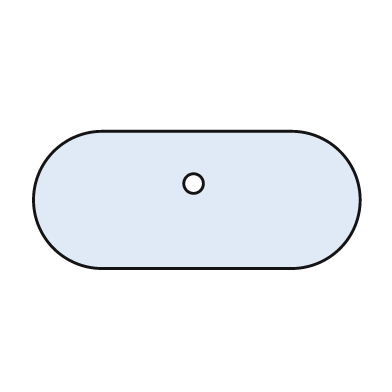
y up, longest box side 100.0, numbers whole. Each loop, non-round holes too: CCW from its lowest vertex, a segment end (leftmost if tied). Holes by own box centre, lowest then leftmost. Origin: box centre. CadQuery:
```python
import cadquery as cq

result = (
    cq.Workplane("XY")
    .moveTo(-29.0, -21.0)
    .lineTo(29.0, -21.0)
    .threePointArc((50.0, 0.0), (29.0, 21.0))
    .lineTo(-29.0, 21.0)
    .threePointArc((-50.0, 0.0), (-29.0, -21.0))
    .close()
    .moveTo(-1.0, 5.0)
    .circle(3.0)
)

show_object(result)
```